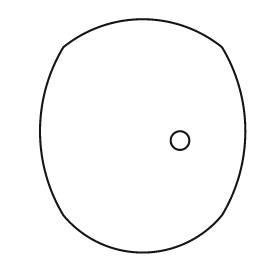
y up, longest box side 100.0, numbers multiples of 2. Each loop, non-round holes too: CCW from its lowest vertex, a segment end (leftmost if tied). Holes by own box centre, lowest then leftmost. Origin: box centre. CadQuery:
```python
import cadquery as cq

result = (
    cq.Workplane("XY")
    .moveTo(-34.0, -34.0)
    .threePointArc((0.0, -50.0), (34.0, -34.0))
    .threePointArc((44.0, 2.0), (34.0, 38.0))
    .threePointArc((0.0, 50.0), (-34.0, 38.0))
    .threePointArc((-44.0, 2.0), (-34.0, -34.0))
    .close()
    .moveTo(16.0, -2.0)
    .circle(4.0)
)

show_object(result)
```